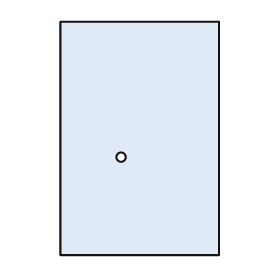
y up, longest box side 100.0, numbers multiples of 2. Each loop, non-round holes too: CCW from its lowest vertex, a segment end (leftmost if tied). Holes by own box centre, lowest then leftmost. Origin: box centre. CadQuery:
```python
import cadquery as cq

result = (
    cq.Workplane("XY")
    .moveTo(-34.0, -50.0)
    .lineTo(34.0, -50.0)
    .lineTo(34.0, 50.0)
    .lineTo(-34.0, 50.0)
    .close()
    .moveTo(-8.0, -8.0)
    .circle(2.0)
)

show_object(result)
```